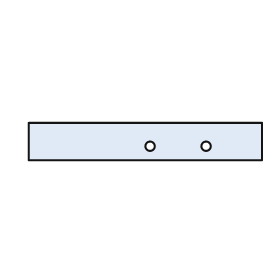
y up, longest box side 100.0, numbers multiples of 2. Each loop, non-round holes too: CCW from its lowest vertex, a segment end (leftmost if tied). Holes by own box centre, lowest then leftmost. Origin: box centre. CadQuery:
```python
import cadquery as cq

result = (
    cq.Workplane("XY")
    .moveTo(-50.0, -8.0)
    .lineTo(50.0, -8.0)
    .lineTo(50.0, 8.0)
    .lineTo(-50.0, 8.0)
    .close()
    .moveTo(2.0, -2.0)
    .circle(2.0)
    .moveTo(26.0, -2.0)
    .circle(2.0)
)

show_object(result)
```